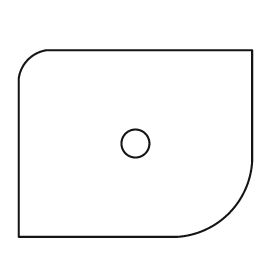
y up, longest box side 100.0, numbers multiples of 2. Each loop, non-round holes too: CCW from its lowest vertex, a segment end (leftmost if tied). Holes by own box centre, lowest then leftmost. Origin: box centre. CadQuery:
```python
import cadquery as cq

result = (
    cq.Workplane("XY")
    .moveTo(-50.0, -40.0)
    .lineTo(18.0, -40.0)
    .threePointArc((40.0, -30.0), (50.0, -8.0))
    .lineTo(50.0, 40.0)
    .lineTo(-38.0, 40.0)
    .threePointArc((-46.0, 36.0), (-50.0, 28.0))
    .close()
    .moveTo(0.0, 0.0)
    .circle(6.0)
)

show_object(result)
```